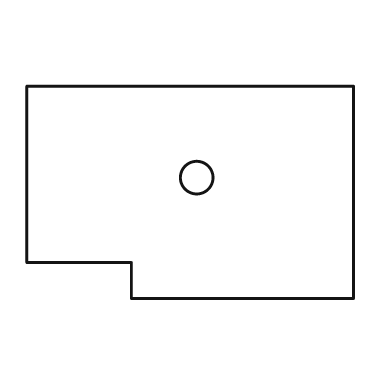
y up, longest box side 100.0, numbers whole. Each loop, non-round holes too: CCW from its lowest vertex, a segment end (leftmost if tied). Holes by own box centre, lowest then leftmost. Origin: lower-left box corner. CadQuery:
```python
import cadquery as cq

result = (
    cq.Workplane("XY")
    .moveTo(32.0, 0.0)
    .lineTo(100.0, 0.0)
    .lineTo(100.0, 65.0)
    .lineTo(0.0, 65.0)
    .lineTo(0.0, 11.0)
    .lineTo(32.0, 11.0)
    .close()
    .moveTo(52.0, 37.0)
    .circle(5.0)
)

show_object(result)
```